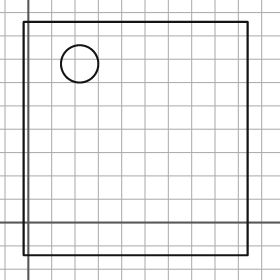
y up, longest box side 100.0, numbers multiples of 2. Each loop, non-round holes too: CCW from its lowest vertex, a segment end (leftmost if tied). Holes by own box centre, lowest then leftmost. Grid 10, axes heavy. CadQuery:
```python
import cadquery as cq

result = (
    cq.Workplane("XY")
    .moveTo(-2.0, -14.0)
    .lineTo(94.0, -14.0)
    .lineTo(94.0, 86.0)
    .lineTo(-2.0, 86.0)
    .close()
    .moveTo(22.0, 68.0)
    .circle(8.0)
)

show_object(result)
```